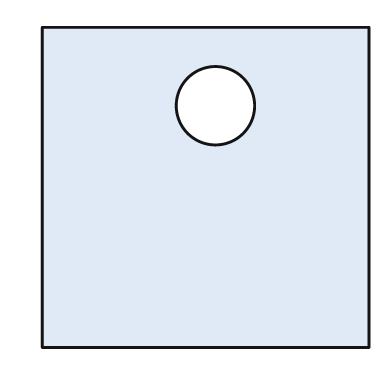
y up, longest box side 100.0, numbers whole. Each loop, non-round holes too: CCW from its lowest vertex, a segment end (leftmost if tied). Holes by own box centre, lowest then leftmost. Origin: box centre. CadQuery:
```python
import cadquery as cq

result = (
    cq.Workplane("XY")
    .moveTo(-50.0, -49.0)
    .lineTo(50.0, -49.0)
    .lineTo(50.0, 49.0)
    .lineTo(-50.0, 49.0)
    .close()
    .moveTo(3.0, 25.0)
    .circle(12.0)
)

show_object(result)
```